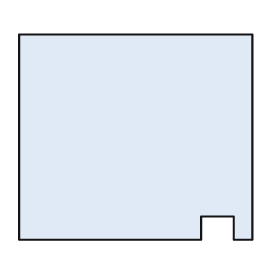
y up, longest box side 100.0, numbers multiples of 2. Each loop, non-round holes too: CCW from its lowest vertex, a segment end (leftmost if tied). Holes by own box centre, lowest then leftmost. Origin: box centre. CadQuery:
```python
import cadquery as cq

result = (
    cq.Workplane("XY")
    .moveTo(-50.0, -44.0)
    .lineTo(28.0, -44.0)
    .lineTo(28.0, -34.0)
    .lineTo(42.0, -34.0)
    .lineTo(42.0, -44.0)
    .lineTo(50.0, -44.0)
    .lineTo(50.0, 44.0)
    .lineTo(-50.0, 44.0)
    .close()
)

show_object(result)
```